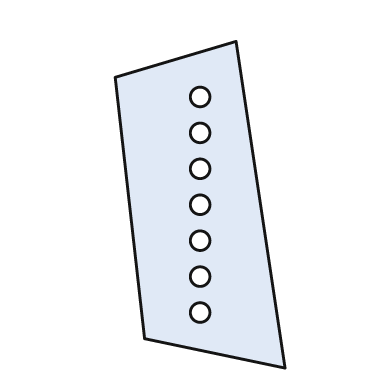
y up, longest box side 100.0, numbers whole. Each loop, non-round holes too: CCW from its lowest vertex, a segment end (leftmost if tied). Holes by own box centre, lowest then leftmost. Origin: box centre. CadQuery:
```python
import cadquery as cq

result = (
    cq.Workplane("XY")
    .moveTo(26.0, -50.0)
    .lineTo(11.0, 50.0)
    .lineTo(-26.0, 39.0)
    .lineTo(-17.0, -41.0)
    .close()
    .moveTo(0.0, -33.0)
    .circle(3.0)
    .moveTo(0.0, -22.0)
    .circle(3.0)
    .moveTo(0.0, -11.0)
    .circle(3.0)
    .moveTo(0.0, 0.0)
    .circle(3.0)
    .moveTo(0.0, 11.0)
    .circle(3.0)
    .moveTo(0.0, 22.0)
    .circle(3.0)
    .moveTo(0.0, 33.0)
    .circle(3.0)
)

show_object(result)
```